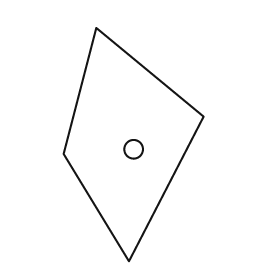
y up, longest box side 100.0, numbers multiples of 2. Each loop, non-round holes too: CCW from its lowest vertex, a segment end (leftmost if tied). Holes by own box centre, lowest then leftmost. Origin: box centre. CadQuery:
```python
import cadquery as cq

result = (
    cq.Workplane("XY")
    .moveTo(-2.0, -50.0)
    .lineTo(30.0, 12.0)
    .lineTo(-16.0, 50.0)
    .lineTo(-30.0, -4.0)
    .close()
    .moveTo(0.0, -2.0)
    .circle(4.0)
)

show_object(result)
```